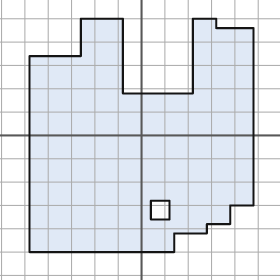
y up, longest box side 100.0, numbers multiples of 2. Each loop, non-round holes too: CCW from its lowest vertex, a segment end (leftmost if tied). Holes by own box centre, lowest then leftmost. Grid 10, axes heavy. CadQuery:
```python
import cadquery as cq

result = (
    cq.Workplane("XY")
    .moveTo(-48.0, -50.0)
    .lineTo(14.0, -50.0)
    .lineTo(14.0, -42.0)
    .lineTo(28.0, -42.0)
    .lineTo(28.0, -38.0)
    .lineTo(38.0, -38.0)
    .lineTo(38.0, -30.0)
    .lineTo(48.0, -30.0)
    .lineTo(48.0, 46.0)
    .lineTo(32.0, 46.0)
    .lineTo(32.0, 50.0)
    .lineTo(22.0, 50.0)
    .lineTo(22.0, 18.0)
    .lineTo(-8.0, 18.0)
    .lineTo(-8.0, 50.0)
    .lineTo(-26.0, 50.0)
    .lineTo(-26.0, 34.0)
    .lineTo(-48.0, 34.0)
    .close()
    .moveTo(4.0, -36.0)
    .lineTo(12.0, -36.0)
    .lineTo(12.0, -28.0)
    .lineTo(4.0, -28.0)
    .close()
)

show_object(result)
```